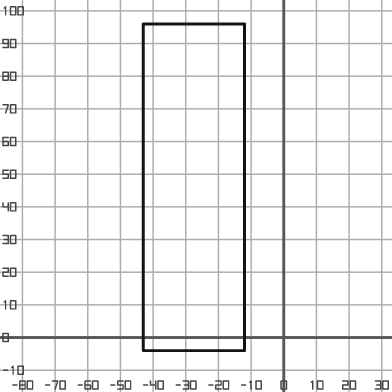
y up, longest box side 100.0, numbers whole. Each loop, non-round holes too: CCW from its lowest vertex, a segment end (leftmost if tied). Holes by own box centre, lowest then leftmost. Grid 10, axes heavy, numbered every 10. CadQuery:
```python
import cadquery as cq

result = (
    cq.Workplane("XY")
    .moveTo(-43.0, -4.0)
    .lineTo(-12.0, -4.0)
    .lineTo(-12.0, 96.0)
    .lineTo(-43.0, 96.0)
    .close()
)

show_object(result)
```